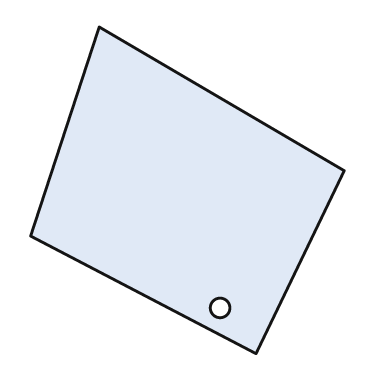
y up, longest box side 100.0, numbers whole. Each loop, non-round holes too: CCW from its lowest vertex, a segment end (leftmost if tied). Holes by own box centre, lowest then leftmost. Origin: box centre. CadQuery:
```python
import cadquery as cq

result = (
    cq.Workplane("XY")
    .moveTo(21.0, -50.0)
    .lineTo(48.0, 6.0)
    .lineTo(-27.0, 50.0)
    .lineTo(-48.0, -14.0)
    .close()
    .moveTo(10.0, -36.0)
    .circle(3.0)
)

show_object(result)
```